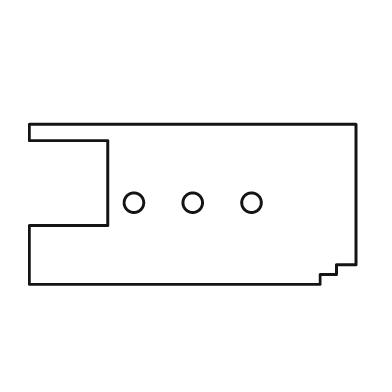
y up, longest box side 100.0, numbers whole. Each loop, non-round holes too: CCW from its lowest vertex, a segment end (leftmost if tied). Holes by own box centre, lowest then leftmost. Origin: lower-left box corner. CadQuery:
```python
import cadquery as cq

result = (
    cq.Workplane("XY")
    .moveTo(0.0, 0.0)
    .lineTo(89.0, 0.0)
    .lineTo(89.0, 3.0)
    .lineTo(94.0, 3.0)
    .lineTo(94.0, 6.0)
    .lineTo(100.0, 6.0)
    .lineTo(100.0, 49.0)
    .lineTo(0.0, 49.0)
    .lineTo(0.0, 44.0)
    .lineTo(24.0, 44.0)
    .lineTo(24.0, 18.0)
    .lineTo(0.0, 18.0)
    .close()
    .moveTo(32.0, 25.0)
    .circle(3.0)
    .moveTo(50.0, 25.0)
    .circle(3.0)
    .moveTo(68.0, 25.0)
    .circle(3.0)
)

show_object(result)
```